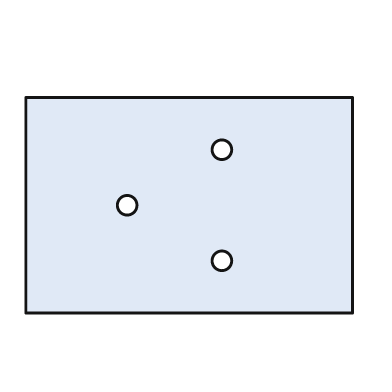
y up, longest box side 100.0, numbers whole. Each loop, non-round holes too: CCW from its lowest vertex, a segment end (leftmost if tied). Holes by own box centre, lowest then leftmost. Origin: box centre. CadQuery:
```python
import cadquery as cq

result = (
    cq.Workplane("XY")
    .moveTo(-50.0, -33.0)
    .lineTo(50.0, -33.0)
    .lineTo(50.0, 33.0)
    .lineTo(-50.0, 33.0)
    .close()
    .moveTo(10.0, -17.0)
    .circle(3.0)
    .moveTo(-19.0, 0.0)
    .circle(3.0)
    .moveTo(10.0, 17.0)
    .circle(3.0)
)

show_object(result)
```